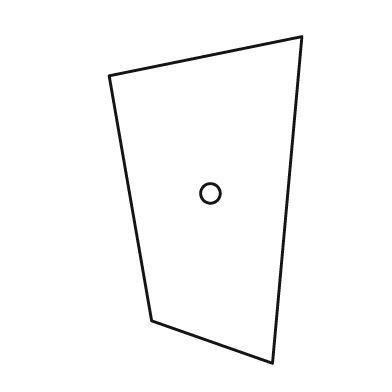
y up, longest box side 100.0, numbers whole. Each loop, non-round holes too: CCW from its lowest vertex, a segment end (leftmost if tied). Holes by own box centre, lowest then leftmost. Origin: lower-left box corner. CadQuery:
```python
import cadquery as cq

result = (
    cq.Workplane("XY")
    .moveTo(50.0, 0.0)
    .lineTo(59.0, 100.0)
    .lineTo(0.0, 88.0)
    .lineTo(13.0, 13.0)
    .close()
    .moveTo(31.0, 52.0)
    .circle(3.0)
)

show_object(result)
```